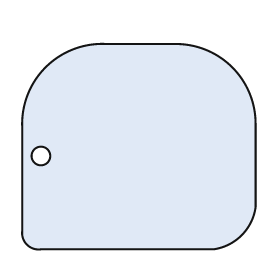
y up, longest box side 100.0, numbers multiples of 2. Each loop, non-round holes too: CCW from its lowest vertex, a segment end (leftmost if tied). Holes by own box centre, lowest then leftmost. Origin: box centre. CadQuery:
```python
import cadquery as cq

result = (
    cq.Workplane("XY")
    .moveTo(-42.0, -44.0)
    .lineTo(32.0, -44.0)
    .threePointArc((44.0, -38.0), (50.0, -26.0))
    .lineTo(50.0, 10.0)
    .threePointArc((40.0, 34.0), (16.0, 44.0))
    .lineTo(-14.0, 44.0)
    .threePointArc((-40.0, 34.0), (-50.0, 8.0))
    .lineTo(-50.0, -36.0)
    .threePointArc((-48.0, -42.0), (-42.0, -44.0))
    .close()
    .moveTo(-42.0, -4.0)
    .circle(4.0)
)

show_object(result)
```